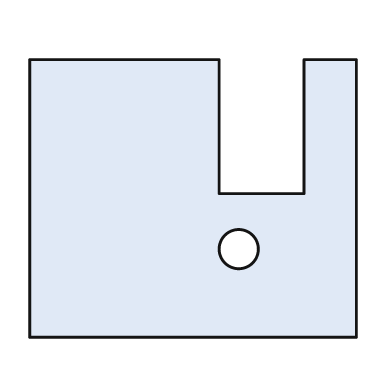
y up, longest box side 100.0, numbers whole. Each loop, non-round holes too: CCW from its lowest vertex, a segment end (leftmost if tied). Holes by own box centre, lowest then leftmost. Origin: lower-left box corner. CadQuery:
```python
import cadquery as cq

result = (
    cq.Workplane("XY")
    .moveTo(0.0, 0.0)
    .lineTo(100.0, 0.0)
    .lineTo(100.0, 85.0)
    .lineTo(84.0, 85.0)
    .lineTo(84.0, 44.0)
    .lineTo(58.0, 44.0)
    .lineTo(58.0, 85.0)
    .lineTo(0.0, 85.0)
    .close()
    .moveTo(64.0, 27.0)
    .circle(6.0)
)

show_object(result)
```